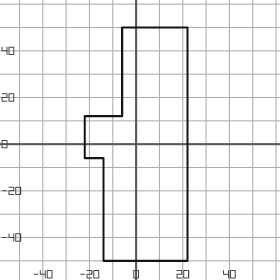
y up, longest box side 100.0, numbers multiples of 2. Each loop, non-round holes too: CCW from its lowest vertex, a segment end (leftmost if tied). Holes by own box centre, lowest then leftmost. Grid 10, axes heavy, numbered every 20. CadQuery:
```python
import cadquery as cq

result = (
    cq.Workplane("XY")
    .moveTo(-14.0, -50.0)
    .lineTo(22.0, -50.0)
    .lineTo(22.0, 50.0)
    .lineTo(-6.0, 50.0)
    .lineTo(-6.0, 12.0)
    .lineTo(-22.0, 12.0)
    .lineTo(-22.0, -6.0)
    .lineTo(-14.0, -6.0)
    .close()
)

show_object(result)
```